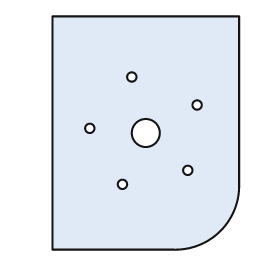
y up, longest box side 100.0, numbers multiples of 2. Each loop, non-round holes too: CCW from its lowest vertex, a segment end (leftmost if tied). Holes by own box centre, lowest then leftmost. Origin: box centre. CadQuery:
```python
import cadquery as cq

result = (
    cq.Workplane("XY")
    .moveTo(-40.0, -50.0)
    .lineTo(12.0, -50.0)
    .threePointArc((32.0, -42.0), (40.0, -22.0))
    .lineTo(40.0, 50.0)
    .lineTo(-40.0, 50.0)
    .close()
    .moveTo(-10.0, -22.0)
    .circle(2.0)
    .moveTo(18.0, -16.0)
    .circle(2.0)
    .moveTo(0.0, 0.0)
    .circle(6.0)
    .moveTo(-24.0, 2.0)
    .circle(2.0)
    .moveTo(22.0, 12.0)
    .circle(2.0)
    .moveTo(-6.0, 24.0)
    .circle(2.0)
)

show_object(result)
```